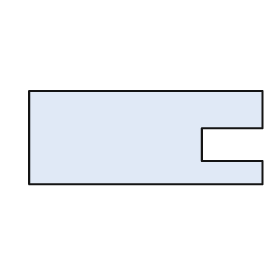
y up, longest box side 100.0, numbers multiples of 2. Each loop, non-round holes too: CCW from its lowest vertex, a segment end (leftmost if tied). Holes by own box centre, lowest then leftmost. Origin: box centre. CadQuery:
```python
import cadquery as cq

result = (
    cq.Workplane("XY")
    .moveTo(-50.0, -20.0)
    .lineTo(50.0, -20.0)
    .lineTo(50.0, -10.0)
    .lineTo(24.0, -10.0)
    .lineTo(24.0, 4.0)
    .lineTo(50.0, 4.0)
    .lineTo(50.0, 20.0)
    .lineTo(-50.0, 20.0)
    .close()
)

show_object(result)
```